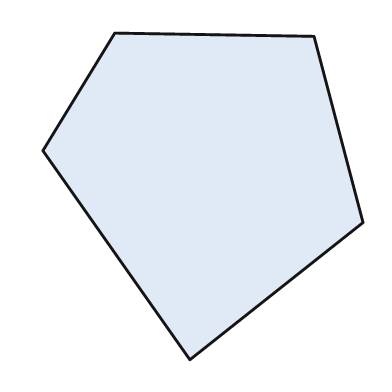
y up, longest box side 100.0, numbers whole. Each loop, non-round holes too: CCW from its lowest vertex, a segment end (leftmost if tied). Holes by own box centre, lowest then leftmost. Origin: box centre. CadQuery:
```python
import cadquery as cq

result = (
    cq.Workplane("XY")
    .moveTo(-4.0, -50.0)
    .lineTo(49.0, -8.0)
    .lineTo(34.0, 49.0)
    .lineTo(-27.0, 50.0)
    .lineTo(-49.0, 14.0)
    .close()
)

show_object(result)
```